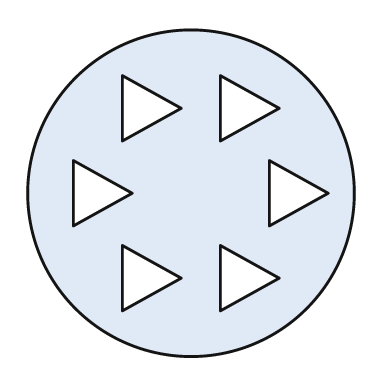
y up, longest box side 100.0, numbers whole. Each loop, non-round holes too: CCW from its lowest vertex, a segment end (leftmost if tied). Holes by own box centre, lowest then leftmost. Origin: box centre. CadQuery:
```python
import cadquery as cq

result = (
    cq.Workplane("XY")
    .moveTo(0.0, 0.0)
    .circle(50.0)
    .moveTo(-21.0, -36.0)
    .lineTo(-3.0, -26.0)
    .lineTo(-21.0, -16.0)
    .close()
    .moveTo(9.0, -36.0)
    .lineTo(27.0, -26.0)
    .lineTo(9.0, -16.0)
    .close()
    .moveTo(-36.0, -10.0)
    .lineTo(-18.0, 0.0)
    .lineTo(-36.0, 10.0)
    .close()
    .moveTo(24.0, -10.0)
    .lineTo(42.0, 0.0)
    .lineTo(24.0, 10.0)
    .close()
    .moveTo(-21.0, 16.0)
    .lineTo(-3.0, 26.0)
    .lineTo(-21.0, 36.0)
    .close()
    .moveTo(9.0, 16.0)
    .lineTo(27.0, 26.0)
    .lineTo(9.0, 36.0)
    .close()
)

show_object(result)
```